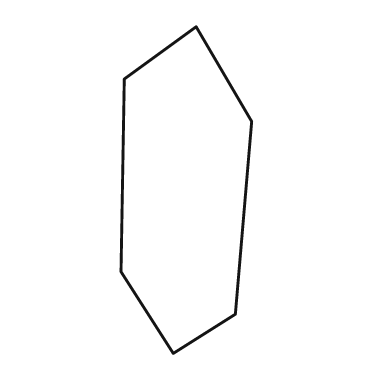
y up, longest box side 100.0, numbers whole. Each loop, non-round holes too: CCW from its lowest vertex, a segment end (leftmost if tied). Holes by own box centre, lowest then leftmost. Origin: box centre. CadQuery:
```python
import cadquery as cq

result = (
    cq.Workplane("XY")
    .moveTo(-4.0, -50.0)
    .lineTo(15.0, -38.0)
    .lineTo(20.0, 21.0)
    .lineTo(3.0, 50.0)
    .lineTo(-19.0, 34.0)
    .lineTo(-20.0, -25.0)
    .close()
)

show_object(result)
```